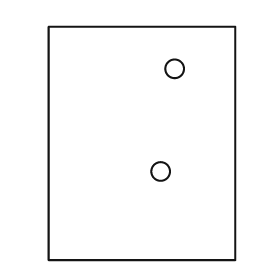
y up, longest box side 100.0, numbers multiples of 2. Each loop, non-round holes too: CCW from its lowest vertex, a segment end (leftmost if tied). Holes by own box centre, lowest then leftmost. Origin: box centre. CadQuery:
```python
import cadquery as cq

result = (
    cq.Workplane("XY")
    .moveTo(-40.0, -50.0)
    .lineTo(40.0, -50.0)
    .lineTo(40.0, 50.0)
    .lineTo(-40.0, 50.0)
    .close()
    .moveTo(8.0, -12.0)
    .circle(4.0)
    .moveTo(14.0, 32.0)
    .circle(4.0)
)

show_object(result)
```